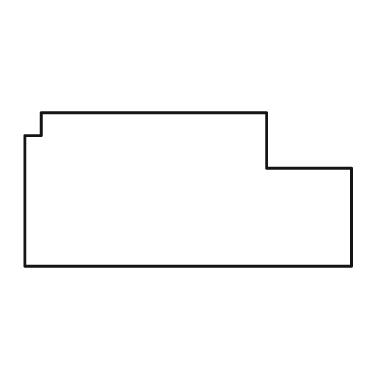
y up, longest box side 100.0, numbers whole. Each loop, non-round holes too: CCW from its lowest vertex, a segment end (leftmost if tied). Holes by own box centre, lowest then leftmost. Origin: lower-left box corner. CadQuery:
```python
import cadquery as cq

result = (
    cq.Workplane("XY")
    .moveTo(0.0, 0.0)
    .lineTo(100.0, 0.0)
    .lineTo(100.0, 30.0)
    .lineTo(74.0, 30.0)
    .lineTo(74.0, 47.0)
    .lineTo(5.0, 47.0)
    .lineTo(5.0, 40.0)
    .lineTo(0.0, 40.0)
    .close()
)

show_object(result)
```